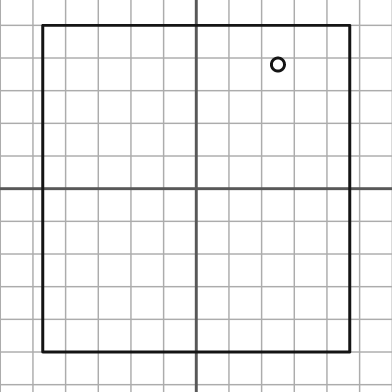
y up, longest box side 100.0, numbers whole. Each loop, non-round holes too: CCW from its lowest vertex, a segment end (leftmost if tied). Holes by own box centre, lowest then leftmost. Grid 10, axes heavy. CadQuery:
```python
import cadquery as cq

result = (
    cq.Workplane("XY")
    .moveTo(-47.0, -50.0)
    .lineTo(47.0, -50.0)
    .lineTo(47.0, 50.0)
    .lineTo(-47.0, 50.0)
    .close()
    .moveTo(25.0, 38.0)
    .circle(2.0)
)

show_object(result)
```